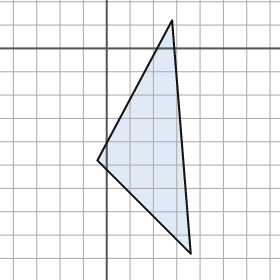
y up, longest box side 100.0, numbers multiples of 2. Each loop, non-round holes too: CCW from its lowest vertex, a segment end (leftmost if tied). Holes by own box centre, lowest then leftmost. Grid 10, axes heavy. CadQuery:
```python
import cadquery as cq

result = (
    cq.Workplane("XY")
    .moveTo(36.0, -88.0)
    .lineTo(28.0, 12.0)
    .lineTo(-4.0, -48.0)
    .close()
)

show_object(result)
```